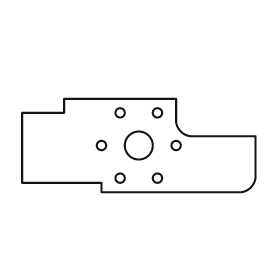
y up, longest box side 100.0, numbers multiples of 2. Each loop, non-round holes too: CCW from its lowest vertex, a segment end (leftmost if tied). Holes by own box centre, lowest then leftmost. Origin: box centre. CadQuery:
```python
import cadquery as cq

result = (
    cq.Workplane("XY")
    .moveTo(-16.0, -20.0)
    .lineTo(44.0, -20.0)
    .threePointArc((48.0, -18.0), (50.0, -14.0))
    .lineTo(50.0, 4.0)
    .lineTo(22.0, 4.0)
    .threePointArc((18.0, 6.0), (16.0, 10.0))
    .lineTo(16.0, 20.0)
    .lineTo(-32.0, 20.0)
    .lineTo(-32.0, 14.0)
    .lineTo(-50.0, 14.0)
    .lineTo(-50.0, -16.0)
    .lineTo(-16.0, -16.0)
    .close()
    .moveTo(-8.0, -14.0)
    .circle(2.0)
    .moveTo(8.0, -14.0)
    .circle(2.0)
    .moveTo(-16.0, 0.0)
    .circle(2.0)
    .moveTo(0.0, 0.0)
    .circle(6.0)
    .moveTo(16.0, 0.0)
    .circle(2.0)
    .moveTo(-8.0, 14.0)
    .circle(2.0)
    .moveTo(8.0, 14.0)
    .circle(2.0)
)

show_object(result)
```